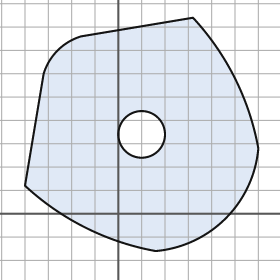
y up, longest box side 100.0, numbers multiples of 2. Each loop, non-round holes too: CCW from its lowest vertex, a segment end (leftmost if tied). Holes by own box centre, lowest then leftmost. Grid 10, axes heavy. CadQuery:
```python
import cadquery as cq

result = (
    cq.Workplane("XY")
    .moveTo(16.0, -16.0)
    .threePointArc((46.0, -2.0), (60.0, 28.0))
    .threePointArc((50.0, 58.0), (32.0, 84.0))
    .lineTo(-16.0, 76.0)
    .threePointArc((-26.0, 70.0), (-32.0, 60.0))
    .lineTo(-40.0, 12.0)
    .threePointArc((-14.0, -6.0), (16.0, -16.0))
    .close()
    .moveTo(10.0, 34.0)
    .circle(10.0)
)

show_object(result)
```